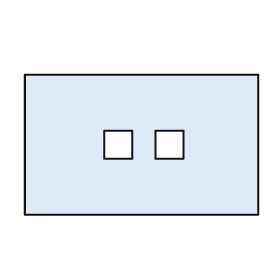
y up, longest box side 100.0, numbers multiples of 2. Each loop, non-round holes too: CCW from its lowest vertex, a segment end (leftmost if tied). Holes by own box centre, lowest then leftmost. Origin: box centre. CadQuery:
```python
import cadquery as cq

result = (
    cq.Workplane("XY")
    .moveTo(-50.0, -30.0)
    .lineTo(50.0, -30.0)
    .lineTo(50.0, 30.0)
    .lineTo(-50.0, 30.0)
    .close()
    .moveTo(-16.0, -6.0)
    .lineTo(-4.0, -6.0)
    .lineTo(-4.0, 6.0)
    .lineTo(-16.0, 6.0)
    .close()
    .moveTo(6.0, -6.0)
    .lineTo(18.0, -6.0)
    .lineTo(18.0, 6.0)
    .lineTo(6.0, 6.0)
    .close()
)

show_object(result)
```